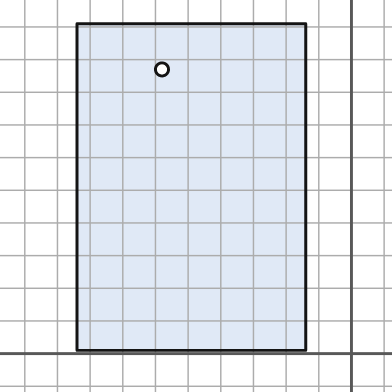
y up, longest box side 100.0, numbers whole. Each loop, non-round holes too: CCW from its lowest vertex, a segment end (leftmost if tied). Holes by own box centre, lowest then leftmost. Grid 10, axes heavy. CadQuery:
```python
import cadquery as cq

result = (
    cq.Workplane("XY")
    .moveTo(-84.0, 1.0)
    .lineTo(-14.0, 1.0)
    .lineTo(-14.0, 101.0)
    .lineTo(-84.0, 101.0)
    .close()
    .moveTo(-58.0, 87.0)
    .circle(2.0)
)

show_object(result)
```